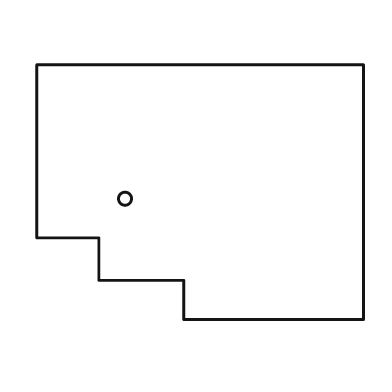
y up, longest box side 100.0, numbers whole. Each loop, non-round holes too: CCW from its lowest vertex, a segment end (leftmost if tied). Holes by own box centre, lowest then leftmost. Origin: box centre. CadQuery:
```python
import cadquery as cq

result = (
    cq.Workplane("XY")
    .moveTo(-5.0, -39.0)
    .lineTo(50.0, -39.0)
    .lineTo(50.0, 39.0)
    .lineTo(-50.0, 39.0)
    .lineTo(-50.0, -14.0)
    .lineTo(-31.0, -14.0)
    .lineTo(-31.0, -27.0)
    .lineTo(-5.0, -27.0)
    .close()
    .moveTo(-23.0, -2.0)
    .circle(2.0)
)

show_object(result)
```